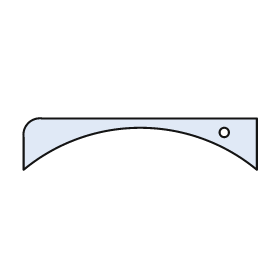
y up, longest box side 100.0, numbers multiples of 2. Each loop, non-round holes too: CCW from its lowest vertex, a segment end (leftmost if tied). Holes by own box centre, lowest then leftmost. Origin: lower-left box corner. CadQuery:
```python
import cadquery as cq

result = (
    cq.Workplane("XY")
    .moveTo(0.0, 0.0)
    .threePointArc((50.0, 18.0), (100.0, 0.0))
    .lineTo(100.0, 22.0)
    .lineTo(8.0, 22.0)
    .threePointArc((2.0, 20.0), (0.0, 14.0))
    .close()
    .moveTo(86.0, 16.0)
    .circle(2.0)
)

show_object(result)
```